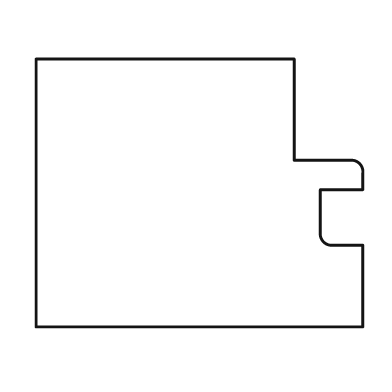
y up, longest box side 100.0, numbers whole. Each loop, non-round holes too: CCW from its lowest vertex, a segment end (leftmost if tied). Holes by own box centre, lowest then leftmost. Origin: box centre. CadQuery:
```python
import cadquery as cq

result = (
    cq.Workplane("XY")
    .moveTo(-50.0, -41.0)
    .lineTo(50.0, -41.0)
    .lineTo(50.0, -16.0)
    .lineTo(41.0, -16.0)
    .threePointArc((38.0, -15.0), (37.0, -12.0))
    .lineTo(37.0, 1.0)
    .lineTo(50.0, 1.0)
    .lineTo(50.0, 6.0)
    .threePointArc((49.0, 9.0), (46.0, 10.0))
    .lineTo(29.0, 10.0)
    .lineTo(29.0, 41.0)
    .lineTo(-50.0, 41.0)
    .close()
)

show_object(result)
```